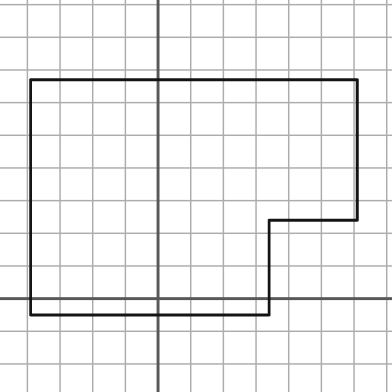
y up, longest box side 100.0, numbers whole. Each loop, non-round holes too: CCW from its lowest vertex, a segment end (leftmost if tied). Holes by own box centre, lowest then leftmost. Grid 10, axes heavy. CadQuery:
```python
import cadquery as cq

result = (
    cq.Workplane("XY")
    .moveTo(-39.0, -5.0)
    .lineTo(34.0, -5.0)
    .lineTo(34.0, 24.0)
    .lineTo(61.0, 24.0)
    .lineTo(61.0, 67.0)
    .lineTo(-39.0, 67.0)
    .close()
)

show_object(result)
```